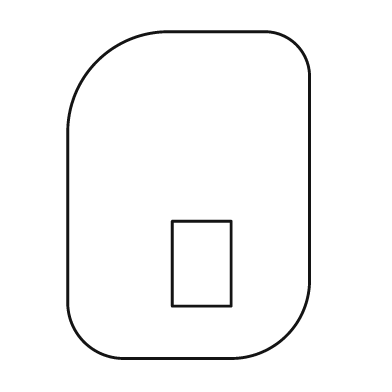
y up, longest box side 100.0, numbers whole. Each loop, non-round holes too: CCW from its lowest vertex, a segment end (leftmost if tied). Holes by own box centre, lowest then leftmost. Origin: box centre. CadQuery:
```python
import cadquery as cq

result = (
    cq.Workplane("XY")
    .moveTo(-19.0, -50.0)
    .lineTo(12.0, -50.0)
    .threePointArc((30.0, -43.0), (37.0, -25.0))
    .lineTo(37.0, 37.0)
    .threePointArc((33.0, 46.0), (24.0, 50.0))
    .lineTo(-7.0, 50.0)
    .threePointArc((-28.0, 41.0), (-37.0, 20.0))
    .lineTo(-37.0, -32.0)
    .threePointArc((-32.0, -45.0), (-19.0, -50.0))
    .close()
    .moveTo(-5.0, -34.0)
    .lineTo(13.0, -34.0)
    .lineTo(13.0, -8.0)
    .lineTo(-5.0, -8.0)
    .close()
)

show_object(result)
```